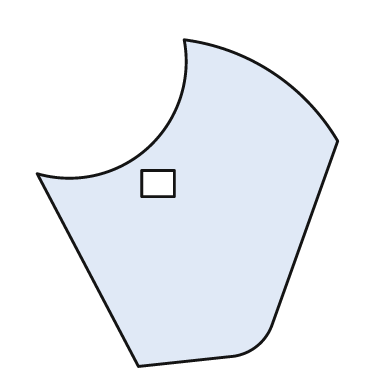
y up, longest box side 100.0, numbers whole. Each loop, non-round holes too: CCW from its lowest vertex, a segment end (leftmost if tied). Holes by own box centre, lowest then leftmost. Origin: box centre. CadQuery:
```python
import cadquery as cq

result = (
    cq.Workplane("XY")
    .moveTo(-15.0, -50.0)
    .lineTo(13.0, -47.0)
    .threePointArc((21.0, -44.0), (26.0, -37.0))
    .lineTo(46.0, 19.0)
    .threePointArc((26.0, 40.0), (-1.0, 50.0))
    .threePointArc((-12.0, 17.0), (-46.0, 9.0))
    .close()
    .moveTo(-14.0, 2.0)
    .lineTo(-4.0, 2.0)
    .lineTo(-4.0, 10.0)
    .lineTo(-14.0, 10.0)
    .close()
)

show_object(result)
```